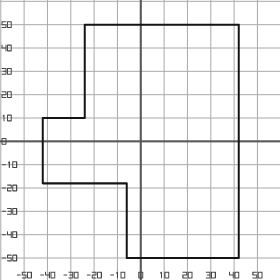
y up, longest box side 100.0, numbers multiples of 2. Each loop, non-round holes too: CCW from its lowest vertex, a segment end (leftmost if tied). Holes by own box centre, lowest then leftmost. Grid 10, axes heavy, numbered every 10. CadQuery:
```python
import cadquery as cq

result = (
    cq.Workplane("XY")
    .moveTo(-6.0, -50.0)
    .lineTo(42.0, -50.0)
    .lineTo(42.0, 50.0)
    .lineTo(-24.0, 50.0)
    .lineTo(-24.0, 10.0)
    .lineTo(-42.0, 10.0)
    .lineTo(-42.0, -18.0)
    .lineTo(-6.0, -18.0)
    .close()
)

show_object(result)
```